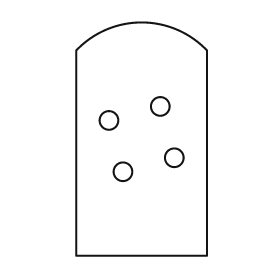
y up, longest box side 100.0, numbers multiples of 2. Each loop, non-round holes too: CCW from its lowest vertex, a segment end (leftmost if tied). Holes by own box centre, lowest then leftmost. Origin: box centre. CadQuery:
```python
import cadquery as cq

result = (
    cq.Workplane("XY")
    .moveTo(-28.0, -50.0)
    .lineTo(28.0, -50.0)
    .lineTo(28.0, 38.0)
    .threePointArc((0.0, 50.0), (-28.0, 38.0))
    .close()
    .moveTo(-8.0, -14.0)
    .circle(4.0)
    .moveTo(14.0, -8.0)
    .circle(4.0)
    .moveTo(-14.0, 8.0)
    .circle(4.0)
    .moveTo(8.0, 14.0)
    .circle(4.0)
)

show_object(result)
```